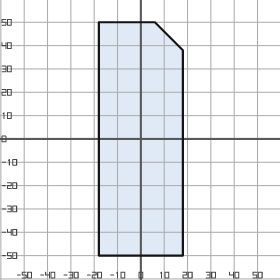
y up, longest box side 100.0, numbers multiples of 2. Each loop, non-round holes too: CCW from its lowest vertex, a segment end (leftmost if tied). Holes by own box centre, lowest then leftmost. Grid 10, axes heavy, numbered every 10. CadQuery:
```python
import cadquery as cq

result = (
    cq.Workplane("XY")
    .moveTo(-18.0, -50.0)
    .lineTo(18.0, -50.0)
    .lineTo(18.0, 38.0)
    .lineTo(6.0, 50.0)
    .lineTo(-18.0, 50.0)
    .close()
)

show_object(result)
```